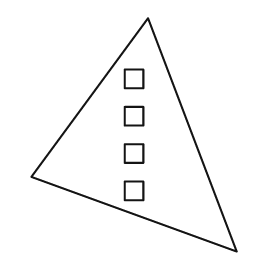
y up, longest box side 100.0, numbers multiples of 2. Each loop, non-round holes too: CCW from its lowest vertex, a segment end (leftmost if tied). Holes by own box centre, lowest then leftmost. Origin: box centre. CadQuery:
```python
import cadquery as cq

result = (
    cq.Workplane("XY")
    .moveTo(44.0, -50.0)
    .lineTo(6.0, 50.0)
    .lineTo(-44.0, -18.0)
    .close()
    .moveTo(-4.0, -28.0)
    .lineTo(4.0, -28.0)
    .lineTo(4.0, -20.0)
    .lineTo(-4.0, -20.0)
    .close()
    .moveTo(-4.0, -12.0)
    .lineTo(4.0, -12.0)
    .lineTo(4.0, -4.0)
    .lineTo(-4.0, -4.0)
    .close()
    .moveTo(-4.0, 4.0)
    .lineTo(4.0, 4.0)
    .lineTo(4.0, 12.0)
    .lineTo(-4.0, 12.0)
    .close()
    .moveTo(-4.0, 20.0)
    .lineTo(4.0, 20.0)
    .lineTo(4.0, 28.0)
    .lineTo(-4.0, 28.0)
    .close()
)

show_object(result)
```